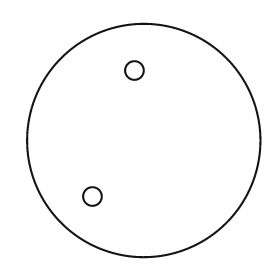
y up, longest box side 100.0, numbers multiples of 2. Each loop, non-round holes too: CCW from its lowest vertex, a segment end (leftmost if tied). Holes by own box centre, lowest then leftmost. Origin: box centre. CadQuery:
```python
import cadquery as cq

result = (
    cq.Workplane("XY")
    .moveTo(0.0, 0.0)
    .circle(50.0)
    .moveTo(-22.0, -24.0)
    .circle(4.0)
    .moveTo(-4.0, 30.0)
    .circle(4.0)
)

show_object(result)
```